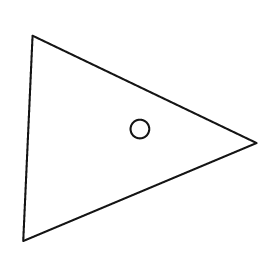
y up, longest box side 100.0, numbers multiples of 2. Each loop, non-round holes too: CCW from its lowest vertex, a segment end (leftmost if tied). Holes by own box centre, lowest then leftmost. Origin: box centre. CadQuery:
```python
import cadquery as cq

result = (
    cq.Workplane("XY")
    .moveTo(-50.0, -44.0)
    .lineTo(50.0, -2.0)
    .lineTo(-46.0, 44.0)
    .close()
    .moveTo(0.0, 4.0)
    .circle(4.0)
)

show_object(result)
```